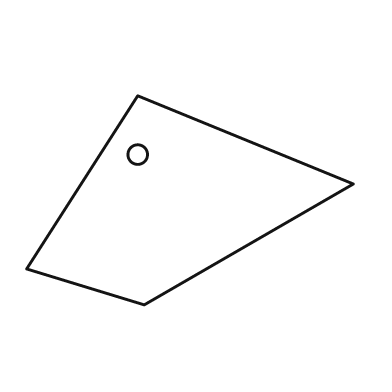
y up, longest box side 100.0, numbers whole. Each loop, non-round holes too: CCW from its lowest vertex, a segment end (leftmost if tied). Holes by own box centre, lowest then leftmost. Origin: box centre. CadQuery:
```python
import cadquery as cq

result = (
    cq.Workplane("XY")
    .moveTo(-14.0, -32.0)
    .lineTo(50.0, 5.0)
    .lineTo(-16.0, 32.0)
    .lineTo(-50.0, -21.0)
    .close()
    .moveTo(-16.0, 14.0)
    .circle(3.0)
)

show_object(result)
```